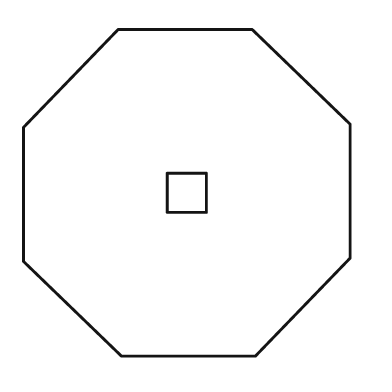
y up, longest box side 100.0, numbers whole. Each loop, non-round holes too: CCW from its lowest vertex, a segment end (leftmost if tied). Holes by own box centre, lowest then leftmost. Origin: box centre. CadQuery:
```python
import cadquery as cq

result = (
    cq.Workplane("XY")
    .moveTo(-20.0, -50.0)
    .lineTo(21.0, -50.0)
    .lineTo(50.0, -20.0)
    .lineTo(50.0, 21.0)
    .lineTo(20.0, 50.0)
    .lineTo(-21.0, 50.0)
    .lineTo(-50.0, 20.0)
    .lineTo(-50.0, -21.0)
    .close()
    .moveTo(-6.0, -6.0)
    .lineTo(6.0, -6.0)
    .lineTo(6.0, 6.0)
    .lineTo(-6.0, 6.0)
    .close()
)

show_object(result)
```